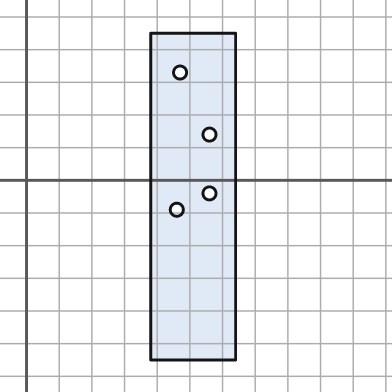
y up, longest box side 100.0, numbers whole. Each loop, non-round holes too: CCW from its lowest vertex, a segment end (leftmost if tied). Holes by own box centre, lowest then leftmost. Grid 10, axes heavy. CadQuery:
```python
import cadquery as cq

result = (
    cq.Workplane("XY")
    .moveTo(38.0, -55.0)
    .lineTo(64.0, -55.0)
    .lineTo(64.0, 45.0)
    .lineTo(38.0, 45.0)
    .close()
    .moveTo(46.0, -9.0)
    .circle(2.0)
    .moveTo(56.0, -4.0)
    .circle(2.0)
    .moveTo(56.0, 14.0)
    .circle(2.0)
    .moveTo(47.0, 33.0)
    .circle(2.0)
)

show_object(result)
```